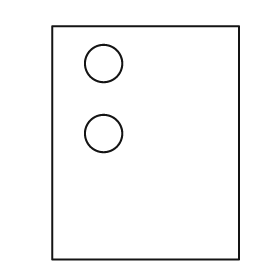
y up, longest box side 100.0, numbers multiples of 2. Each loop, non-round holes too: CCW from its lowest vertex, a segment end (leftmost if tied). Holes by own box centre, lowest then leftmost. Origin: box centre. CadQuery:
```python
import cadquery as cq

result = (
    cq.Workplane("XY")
    .moveTo(-40.0, -50.0)
    .lineTo(40.0, -50.0)
    .lineTo(40.0, 50.0)
    .lineTo(-40.0, 50.0)
    .close()
    .moveTo(-18.0, 4.0)
    .circle(8.0)
    .moveTo(-18.0, 34.0)
    .circle(8.0)
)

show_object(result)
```